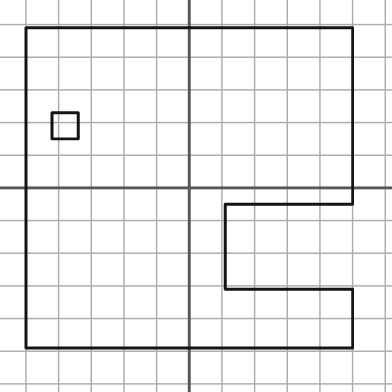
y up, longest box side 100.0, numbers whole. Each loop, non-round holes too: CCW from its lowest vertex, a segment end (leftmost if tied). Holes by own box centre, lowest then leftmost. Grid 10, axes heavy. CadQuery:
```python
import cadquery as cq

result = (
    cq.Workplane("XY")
    .moveTo(-50.0, -49.0)
    .lineTo(50.0, -49.0)
    .lineTo(50.0, -31.0)
    .lineTo(11.0, -31.0)
    .lineTo(11.0, -5.0)
    .lineTo(50.0, -5.0)
    .lineTo(50.0, 49.0)
    .lineTo(-50.0, 49.0)
    .close()
    .moveTo(-42.0, 15.0)
    .lineTo(-34.0, 15.0)
    .lineTo(-34.0, 23.0)
    .lineTo(-42.0, 23.0)
    .close()
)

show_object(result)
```